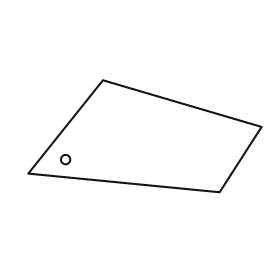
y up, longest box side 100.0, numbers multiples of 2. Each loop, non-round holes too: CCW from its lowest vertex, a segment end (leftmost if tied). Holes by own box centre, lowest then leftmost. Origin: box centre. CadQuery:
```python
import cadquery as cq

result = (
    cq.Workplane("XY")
    .moveTo(32.0, -24.0)
    .lineTo(50.0, 4.0)
    .lineTo(-18.0, 24.0)
    .lineTo(-50.0, -16.0)
    .close()
    .moveTo(-34.0, -10.0)
    .circle(2.0)
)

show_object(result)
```